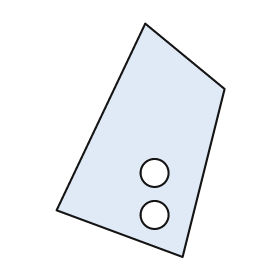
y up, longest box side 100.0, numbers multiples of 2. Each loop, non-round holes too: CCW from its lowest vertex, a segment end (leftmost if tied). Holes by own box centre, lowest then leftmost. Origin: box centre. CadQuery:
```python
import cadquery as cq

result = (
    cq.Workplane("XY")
    .moveTo(18.0, -50.0)
    .lineTo(36.0, 22.0)
    .lineTo(2.0, 50.0)
    .lineTo(-36.0, -30.0)
    .close()
    .moveTo(6.0, -32.0)
    .circle(6.0)
    .moveTo(6.0, -14.0)
    .circle(6.0)
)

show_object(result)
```